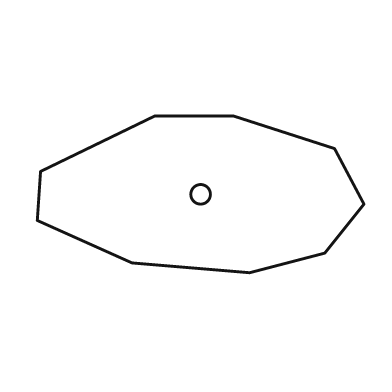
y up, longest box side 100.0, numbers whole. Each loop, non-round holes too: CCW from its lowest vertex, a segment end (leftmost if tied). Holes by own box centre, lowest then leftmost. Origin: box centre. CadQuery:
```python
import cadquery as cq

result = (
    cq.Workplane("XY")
    .moveTo(15.0, -24.0)
    .lineTo(38.0, -18.0)
    .lineTo(50.0, -3.0)
    .lineTo(41.0, 14.0)
    .lineTo(10.0, 24.0)
    .lineTo(-14.0, 24.0)
    .lineTo(-49.0, 7.0)
    .lineTo(-50.0, -8.0)
    .lineTo(-21.0, -21.0)
    .close()
    .moveTo(0.0, 0.0)
    .circle(3.0)
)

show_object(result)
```